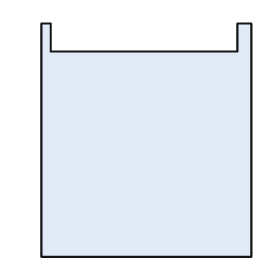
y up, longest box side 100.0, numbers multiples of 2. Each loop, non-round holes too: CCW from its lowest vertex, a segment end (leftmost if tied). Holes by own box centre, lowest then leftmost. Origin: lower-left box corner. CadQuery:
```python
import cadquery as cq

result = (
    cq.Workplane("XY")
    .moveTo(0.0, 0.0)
    .lineTo(90.0, 0.0)
    .lineTo(90.0, 100.0)
    .lineTo(84.0, 100.0)
    .lineTo(84.0, 88.0)
    .lineTo(4.0, 88.0)
    .lineTo(4.0, 100.0)
    .lineTo(0.0, 100.0)
    .close()
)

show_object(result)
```